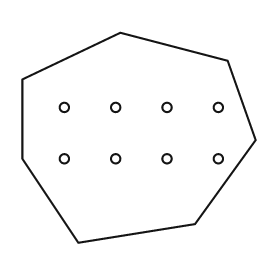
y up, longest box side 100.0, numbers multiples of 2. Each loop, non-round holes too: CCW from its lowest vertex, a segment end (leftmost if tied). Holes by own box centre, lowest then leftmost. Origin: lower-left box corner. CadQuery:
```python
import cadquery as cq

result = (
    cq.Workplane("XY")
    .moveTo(24.0, 0.0)
    .lineTo(74.0, 8.0)
    .lineTo(100.0, 44.0)
    .lineTo(88.0, 78.0)
    .lineTo(42.0, 90.0)
    .lineTo(0.0, 70.0)
    .lineTo(0.0, 36.0)
    .close()
    .moveTo(18.0, 36.0)
    .circle(2.0)
    .moveTo(40.0, 36.0)
    .circle(2.0)
    .moveTo(62.0, 36.0)
    .circle(2.0)
    .moveTo(84.0, 36.0)
    .circle(2.0)
    .moveTo(18.0, 58.0)
    .circle(2.0)
    .moveTo(40.0, 58.0)
    .circle(2.0)
    .moveTo(62.0, 58.0)
    .circle(2.0)
    .moveTo(84.0, 58.0)
    .circle(2.0)
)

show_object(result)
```